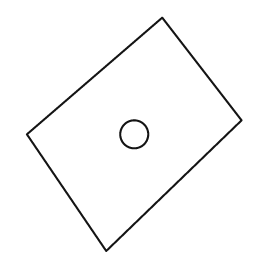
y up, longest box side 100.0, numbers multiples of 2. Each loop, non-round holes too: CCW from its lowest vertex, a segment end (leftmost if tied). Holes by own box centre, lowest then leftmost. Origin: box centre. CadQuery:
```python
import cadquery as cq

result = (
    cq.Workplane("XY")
    .moveTo(-12.0, -50.0)
    .lineTo(46.0, 6.0)
    .lineTo(12.0, 50.0)
    .lineTo(-46.0, 0.0)
    .close()
    .moveTo(0.0, 0.0)
    .circle(6.0)
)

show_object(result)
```